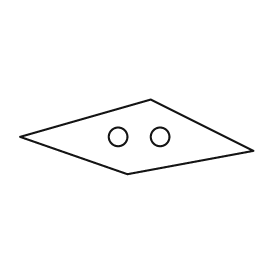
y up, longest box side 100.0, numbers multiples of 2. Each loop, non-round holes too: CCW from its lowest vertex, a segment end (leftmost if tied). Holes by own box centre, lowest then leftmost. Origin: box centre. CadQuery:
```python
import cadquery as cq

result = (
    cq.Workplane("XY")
    .moveTo(-4.0, -16.0)
    .lineTo(50.0, -6.0)
    .lineTo(6.0, 16.0)
    .lineTo(-50.0, 0.0)
    .close()
    .moveTo(-8.0, 0.0)
    .circle(4.0)
    .moveTo(10.0, 0.0)
    .circle(4.0)
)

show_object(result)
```